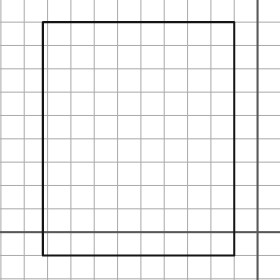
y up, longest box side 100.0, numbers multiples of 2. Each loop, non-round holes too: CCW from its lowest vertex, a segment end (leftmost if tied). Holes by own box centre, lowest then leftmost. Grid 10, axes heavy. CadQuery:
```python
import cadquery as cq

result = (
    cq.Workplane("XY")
    .moveTo(-92.0, -10.0)
    .lineTo(-10.0, -10.0)
    .lineTo(-10.0, 90.0)
    .lineTo(-92.0, 90.0)
    .close()
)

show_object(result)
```